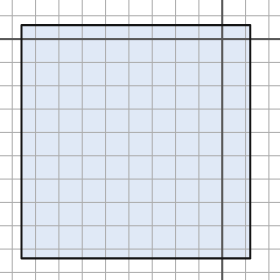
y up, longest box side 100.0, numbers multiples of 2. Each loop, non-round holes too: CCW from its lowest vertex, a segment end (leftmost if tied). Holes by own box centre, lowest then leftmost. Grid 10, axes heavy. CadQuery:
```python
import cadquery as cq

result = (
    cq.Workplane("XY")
    .moveTo(-86.0, -94.0)
    .lineTo(12.0, -94.0)
    .lineTo(12.0, 6.0)
    .lineTo(-86.0, 6.0)
    .close()
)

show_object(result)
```